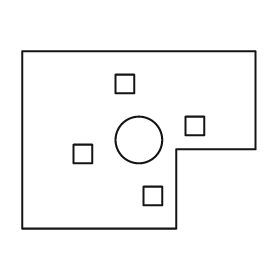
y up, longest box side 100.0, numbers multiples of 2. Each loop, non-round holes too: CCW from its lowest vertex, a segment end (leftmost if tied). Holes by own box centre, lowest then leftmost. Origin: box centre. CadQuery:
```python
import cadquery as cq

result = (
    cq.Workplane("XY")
    .moveTo(-50.0, -38.0)
    .lineTo(16.0, -38.0)
    .lineTo(16.0, -4.0)
    .lineTo(50.0, -4.0)
    .lineTo(50.0, 38.0)
    .lineTo(-50.0, 38.0)
    .close()
    .moveTo(2.0, -28.0)
    .lineTo(10.0, -28.0)
    .lineTo(10.0, -20.0)
    .lineTo(2.0, -20.0)
    .close()
    .moveTo(-28.0, -10.0)
    .lineTo(-20.0, -10.0)
    .lineTo(-20.0, -2.0)
    .lineTo(-28.0, -2.0)
    .close()
    .moveTo(0.0, 0.0)
    .circle(10.0)
    .moveTo(20.0, 2.0)
    .lineTo(28.0, 2.0)
    .lineTo(28.0, 10.0)
    .lineTo(20.0, 10.0)
    .close()
    .moveTo(-10.0, 20.0)
    .lineTo(-2.0, 20.0)
    .lineTo(-2.0, 28.0)
    .lineTo(-10.0, 28.0)
    .close()
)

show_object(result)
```